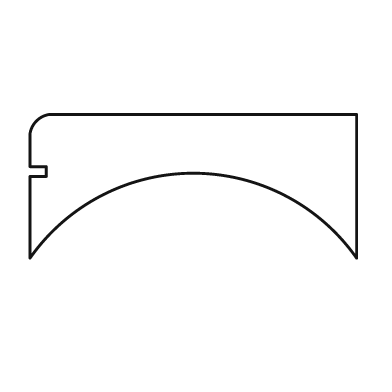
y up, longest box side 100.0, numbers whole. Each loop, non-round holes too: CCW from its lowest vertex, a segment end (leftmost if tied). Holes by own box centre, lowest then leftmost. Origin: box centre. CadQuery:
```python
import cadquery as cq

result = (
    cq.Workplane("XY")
    .moveTo(-50.0, -22.0)
    .threePointArc((0.0, 4.0), (50.0, -22.0))
    .lineTo(50.0, 22.0)
    .lineTo(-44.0, 22.0)
    .threePointArc((-48.0, 20.0), (-50.0, 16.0))
    .lineTo(-50.0, 6.0)
    .lineTo(-45.0, 6.0)
    .lineTo(-45.0, 3.0)
    .lineTo(-50.0, 3.0)
    .close()
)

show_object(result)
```